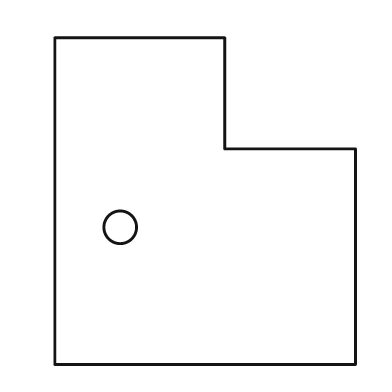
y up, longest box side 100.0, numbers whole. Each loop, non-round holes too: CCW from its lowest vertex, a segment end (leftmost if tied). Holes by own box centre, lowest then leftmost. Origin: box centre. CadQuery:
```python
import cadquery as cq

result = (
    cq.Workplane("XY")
    .moveTo(-46.0, -50.0)
    .lineTo(46.0, -50.0)
    .lineTo(46.0, 16.0)
    .lineTo(6.0, 16.0)
    .lineTo(6.0, 50.0)
    .lineTo(-46.0, 50.0)
    .close()
    .moveTo(-26.0, -8.0)
    .circle(5.0)
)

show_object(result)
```